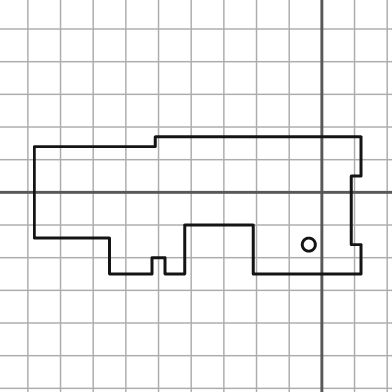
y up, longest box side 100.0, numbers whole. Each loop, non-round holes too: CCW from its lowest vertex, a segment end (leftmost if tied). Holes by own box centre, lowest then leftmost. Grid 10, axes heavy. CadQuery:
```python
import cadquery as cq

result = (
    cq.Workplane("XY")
    .moveTo(-65.0, -25.0)
    .lineTo(-52.0, -25.0)
    .lineTo(-52.0, -20.0)
    .lineTo(-48.0, -20.0)
    .lineTo(-48.0, -25.0)
    .lineTo(-42.0, -25.0)
    .lineTo(-42.0, -10.0)
    .lineTo(-21.0, -10.0)
    .lineTo(-21.0, -25.0)
    .lineTo(12.0, -25.0)
    .lineTo(12.0, -16.0)
    .lineTo(9.0, -16.0)
    .lineTo(9.0, 5.0)
    .lineTo(12.0, 5.0)
    .lineTo(12.0, 17.0)
    .lineTo(-51.0, 17.0)
    .lineTo(-51.0, 14.0)
    .lineTo(-88.0, 14.0)
    .lineTo(-88.0, -14.0)
    .lineTo(-65.0, -14.0)
    .close()
    .moveTo(-4.0, -16.0)
    .circle(2.0)
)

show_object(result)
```